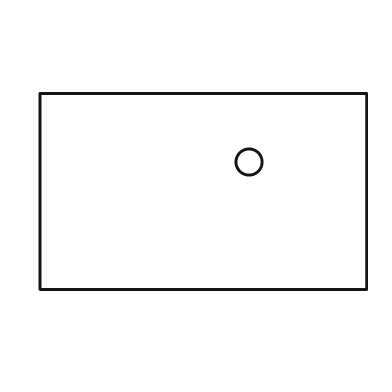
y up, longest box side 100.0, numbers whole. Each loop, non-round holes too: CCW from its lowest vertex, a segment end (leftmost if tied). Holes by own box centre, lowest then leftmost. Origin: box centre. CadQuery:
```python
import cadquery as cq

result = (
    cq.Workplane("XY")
    .moveTo(-50.0, -30.0)
    .lineTo(50.0, -30.0)
    .lineTo(50.0, 30.0)
    .lineTo(-50.0, 30.0)
    .close()
    .moveTo(14.0, 9.0)
    .circle(4.0)
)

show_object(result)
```